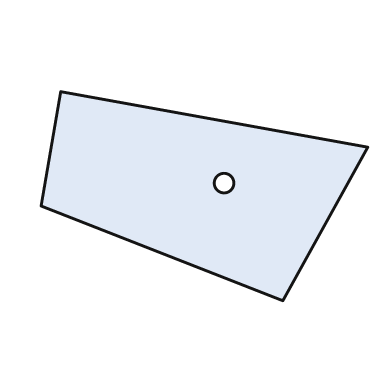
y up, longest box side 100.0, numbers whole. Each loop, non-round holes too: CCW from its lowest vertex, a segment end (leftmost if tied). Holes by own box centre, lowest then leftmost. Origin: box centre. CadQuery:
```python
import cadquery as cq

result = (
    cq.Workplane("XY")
    .moveTo(24.0, -32.0)
    .lineTo(50.0, 15.0)
    .lineTo(-44.0, 32.0)
    .lineTo(-50.0, -3.0)
    .close()
    .moveTo(6.0, 4.0)
    .circle(3.0)
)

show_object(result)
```